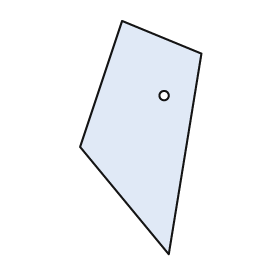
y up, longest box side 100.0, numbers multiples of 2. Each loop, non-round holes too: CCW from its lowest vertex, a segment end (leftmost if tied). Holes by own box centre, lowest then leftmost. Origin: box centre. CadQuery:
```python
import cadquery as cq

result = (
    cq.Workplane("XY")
    .moveTo(12.0, -50.0)
    .lineTo(26.0, 36.0)
    .lineTo(-8.0, 50.0)
    .lineTo(-26.0, -4.0)
    .close()
    .moveTo(10.0, 18.0)
    .circle(2.0)
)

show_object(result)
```